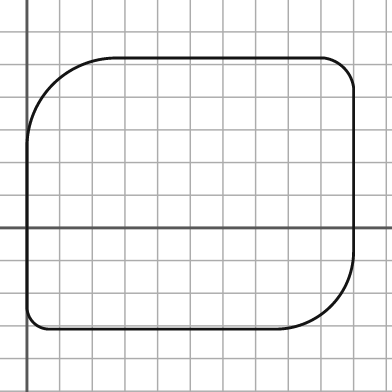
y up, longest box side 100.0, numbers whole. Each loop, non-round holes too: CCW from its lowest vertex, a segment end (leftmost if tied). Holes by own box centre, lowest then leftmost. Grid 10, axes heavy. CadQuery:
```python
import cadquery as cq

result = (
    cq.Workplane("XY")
    .moveTo(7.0, -31.0)
    .lineTo(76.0, -31.0)
    .threePointArc((93.0, -24.0), (100.0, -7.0))
    .lineTo(100.0, 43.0)
    .threePointArc((97.0, 49.0), (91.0, 52.0))
    .lineTo(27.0, 52.0)
    .threePointArc((8.0, 44.0), (0.0, 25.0))
    .lineTo(0.0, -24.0)
    .threePointArc((2.0, -29.0), (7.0, -31.0))
    .close()
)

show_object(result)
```